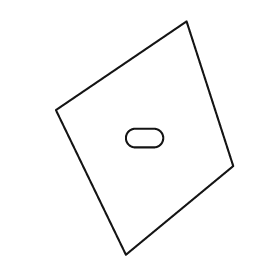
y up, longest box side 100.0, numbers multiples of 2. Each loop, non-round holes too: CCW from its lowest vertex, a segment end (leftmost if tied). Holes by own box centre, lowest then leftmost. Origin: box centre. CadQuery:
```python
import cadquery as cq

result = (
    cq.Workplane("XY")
    .moveTo(-8.0, -50.0)
    .lineTo(38.0, -12.0)
    .lineTo(18.0, 50.0)
    .lineTo(-38.0, 12.0)
    .close()
    .moveTo(-4.0, -4.0)
    .lineTo(4.0, -4.0)
    .threePointArc((8.0, 0.0), (4.0, 4.0))
    .lineTo(-4.0, 4.0)
    .threePointArc((-8.0, 0.0), (-4.0, -4.0))
    .close()
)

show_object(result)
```